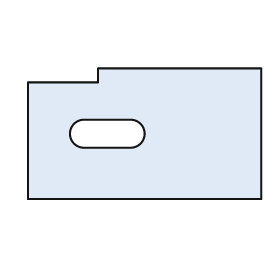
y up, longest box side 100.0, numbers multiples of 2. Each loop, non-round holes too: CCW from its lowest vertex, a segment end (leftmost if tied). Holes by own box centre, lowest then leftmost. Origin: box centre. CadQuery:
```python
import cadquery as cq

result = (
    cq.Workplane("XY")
    .moveTo(-50.0, -28.0)
    .lineTo(50.0, -28.0)
    .lineTo(50.0, 28.0)
    .lineTo(-20.0, 28.0)
    .lineTo(-20.0, 22.0)
    .lineTo(-50.0, 22.0)
    .close()
    .moveTo(-26.0, -6.0)
    .lineTo(-6.0, -6.0)
    .threePointArc((0.0, 0.0), (-6.0, 6.0))
    .lineTo(-26.0, 6.0)
    .threePointArc((-32.0, 0.0), (-26.0, -6.0))
    .close()
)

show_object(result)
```